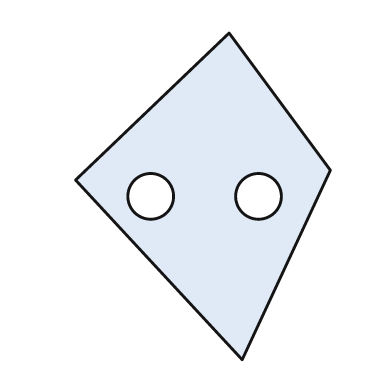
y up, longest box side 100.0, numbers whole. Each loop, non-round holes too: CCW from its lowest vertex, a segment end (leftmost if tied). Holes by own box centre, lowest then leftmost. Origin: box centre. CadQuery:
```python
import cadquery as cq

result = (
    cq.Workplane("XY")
    .moveTo(12.0, -50.0)
    .lineTo(39.0, 8.0)
    .lineTo(8.0, 50.0)
    .lineTo(-39.0, 5.0)
    .close()
    .moveTo(-16.0, 0.0)
    .circle(7.0)
    .moveTo(17.0, 0.0)
    .circle(7.0)
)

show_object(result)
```